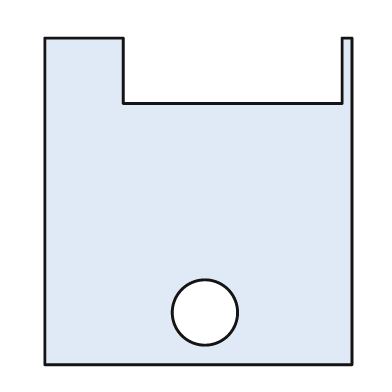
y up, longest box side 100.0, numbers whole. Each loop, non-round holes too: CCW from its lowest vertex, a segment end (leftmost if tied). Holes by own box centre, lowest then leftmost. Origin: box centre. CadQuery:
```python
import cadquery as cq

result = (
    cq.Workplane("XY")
    .moveTo(-47.0, -50.0)
    .lineTo(47.0, -50.0)
    .lineTo(47.0, 50.0)
    .lineTo(44.0, 50.0)
    .lineTo(44.0, 30.0)
    .lineTo(-23.0, 30.0)
    .lineTo(-23.0, 50.0)
    .lineTo(-47.0, 50.0)
    .close()
    .moveTo(2.0, -34.0)
    .circle(10.0)
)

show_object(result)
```